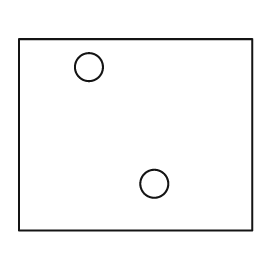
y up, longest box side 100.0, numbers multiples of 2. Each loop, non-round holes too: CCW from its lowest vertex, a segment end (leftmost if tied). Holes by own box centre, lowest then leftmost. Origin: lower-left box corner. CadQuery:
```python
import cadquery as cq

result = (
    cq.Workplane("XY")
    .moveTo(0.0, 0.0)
    .lineTo(100.0, 0.0)
    .lineTo(100.0, 82.0)
    .lineTo(0.0, 82.0)
    .close()
    .moveTo(58.0, 20.0)
    .circle(6.0)
    .moveTo(30.0, 70.0)
    .circle(6.0)
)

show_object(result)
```